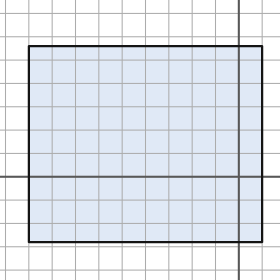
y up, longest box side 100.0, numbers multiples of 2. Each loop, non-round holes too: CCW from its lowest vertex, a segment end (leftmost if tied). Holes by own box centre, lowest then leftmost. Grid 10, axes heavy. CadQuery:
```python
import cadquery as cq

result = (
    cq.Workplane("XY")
    .moveTo(-90.0, -28.0)
    .lineTo(10.0, -28.0)
    .lineTo(10.0, 56.0)
    .lineTo(-90.0, 56.0)
    .close()
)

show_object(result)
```